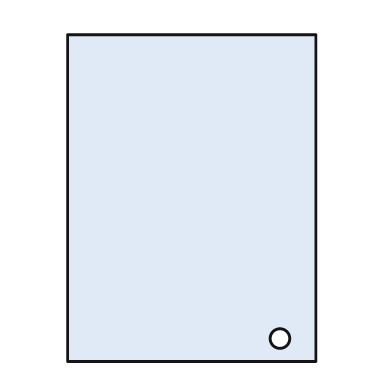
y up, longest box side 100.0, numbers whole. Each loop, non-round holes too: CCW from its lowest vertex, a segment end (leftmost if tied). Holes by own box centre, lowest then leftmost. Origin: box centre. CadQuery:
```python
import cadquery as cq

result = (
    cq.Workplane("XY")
    .moveTo(-38.0, -50.0)
    .lineTo(38.0, -50.0)
    .lineTo(38.0, 50.0)
    .lineTo(-38.0, 50.0)
    .close()
    .moveTo(27.0, -43.0)
    .circle(3.0)
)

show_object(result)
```